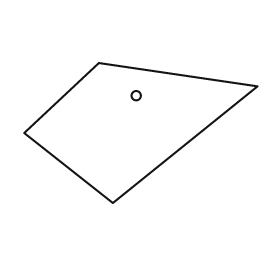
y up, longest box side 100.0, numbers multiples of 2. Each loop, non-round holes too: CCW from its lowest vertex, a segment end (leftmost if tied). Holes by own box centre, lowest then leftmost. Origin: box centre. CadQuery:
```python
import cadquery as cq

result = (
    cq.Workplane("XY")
    .moveTo(-12.0, -30.0)
    .lineTo(50.0, 20.0)
    .lineTo(-18.0, 30.0)
    .lineTo(-50.0, 0.0)
    .close()
    .moveTo(-2.0, 16.0)
    .circle(2.0)
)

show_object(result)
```